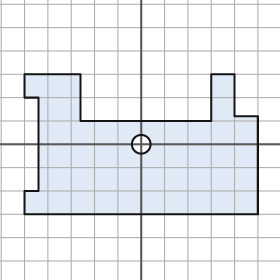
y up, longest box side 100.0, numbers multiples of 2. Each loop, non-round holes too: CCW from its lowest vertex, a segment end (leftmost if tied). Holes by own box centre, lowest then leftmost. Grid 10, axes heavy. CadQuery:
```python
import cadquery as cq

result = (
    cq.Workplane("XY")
    .moveTo(-50.0, -30.0)
    .lineTo(50.0, -30.0)
    .lineTo(50.0, 12.0)
    .lineTo(40.0, 12.0)
    .lineTo(40.0, 30.0)
    .lineTo(30.0, 30.0)
    .lineTo(30.0, 10.0)
    .lineTo(-26.0, 10.0)
    .lineTo(-26.0, 30.0)
    .lineTo(-50.0, 30.0)
    .lineTo(-50.0, 20.0)
    .lineTo(-44.0, 20.0)
    .lineTo(-44.0, -20.0)
    .lineTo(-50.0, -20.0)
    .close()
    .moveTo(0.0, 0.0)
    .circle(4.0)
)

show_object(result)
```